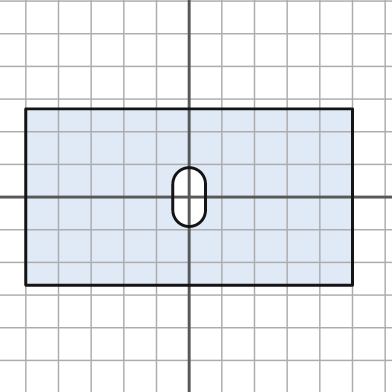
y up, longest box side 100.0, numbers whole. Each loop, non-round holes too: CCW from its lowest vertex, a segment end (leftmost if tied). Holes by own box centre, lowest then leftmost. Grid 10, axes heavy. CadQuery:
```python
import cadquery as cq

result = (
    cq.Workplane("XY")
    .moveTo(-50.0, -27.0)
    .lineTo(50.0, -27.0)
    .lineTo(50.0, 27.0)
    .lineTo(-50.0, 27.0)
    .close()
    .moveTo(-5.0, -4.0)
    .threePointArc((0.0, -9.0), (5.0, -4.0))
    .lineTo(5.0, 4.0)
    .threePointArc((0.0, 9.0), (-5.0, 4.0))
    .close()
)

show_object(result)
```